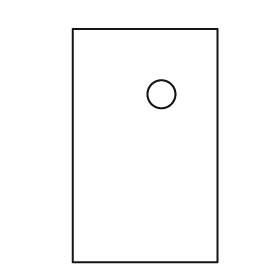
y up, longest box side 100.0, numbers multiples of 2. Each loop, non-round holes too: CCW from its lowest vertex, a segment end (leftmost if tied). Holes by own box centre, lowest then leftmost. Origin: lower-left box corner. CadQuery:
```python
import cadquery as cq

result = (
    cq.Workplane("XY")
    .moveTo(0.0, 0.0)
    .lineTo(62.0, 0.0)
    .lineTo(62.0, 100.0)
    .lineTo(0.0, 100.0)
    .close()
    .moveTo(38.0, 72.0)
    .circle(6.0)
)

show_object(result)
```